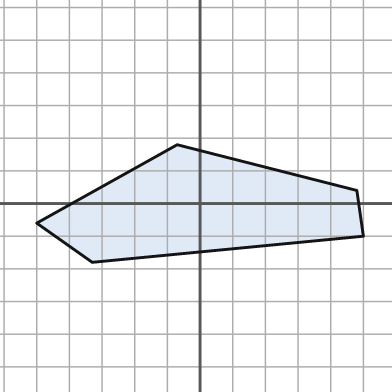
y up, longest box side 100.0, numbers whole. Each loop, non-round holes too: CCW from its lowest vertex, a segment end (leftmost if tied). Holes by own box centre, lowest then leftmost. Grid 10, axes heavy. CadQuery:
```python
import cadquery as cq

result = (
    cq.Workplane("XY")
    .moveTo(-33.0, -18.0)
    .lineTo(50.0, -10.0)
    .lineTo(48.0, 4.0)
    .lineTo(-7.0, 18.0)
    .lineTo(-50.0, -6.0)
    .close()
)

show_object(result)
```